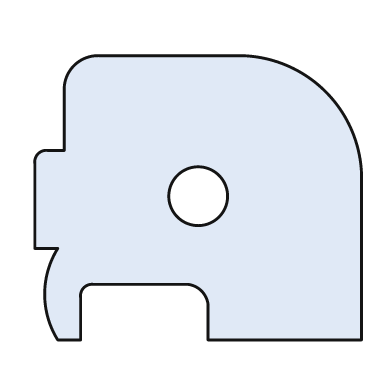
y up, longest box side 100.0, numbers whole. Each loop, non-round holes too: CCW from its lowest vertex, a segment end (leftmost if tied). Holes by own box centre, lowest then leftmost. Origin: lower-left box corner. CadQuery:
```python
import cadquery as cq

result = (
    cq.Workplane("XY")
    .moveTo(7.0, 0.0)
    .lineTo(14.0, 0.0)
    .lineTo(14.0, 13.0)
    .threePointArc((15.0, 16.0), (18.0, 17.0))
    .lineTo(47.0, 17.0)
    .threePointArc((51.0, 15.0), (53.0, 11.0))
    .lineTo(53.0, 0.0)
    .lineTo(100.0, 0.0)
    .lineTo(100.0, 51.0)
    .threePointArc((89.0, 76.0), (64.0, 87.0))
    .lineTo(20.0, 87.0)
    .threePointArc((12.0, 84.0), (9.0, 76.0))
    .lineTo(9.0, 58.0)
    .lineTo(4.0, 58.0)
    .threePointArc((1.0, 57.0), (0.0, 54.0))
    .lineTo(0.0, 28.0)
    .lineTo(7.0, 28.0)
    .threePointArc((3.0, 14.0), (7.0, 0.0))
    .close()
    .moveTo(50.0, 44.0)
    .circle(9.0)
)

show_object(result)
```